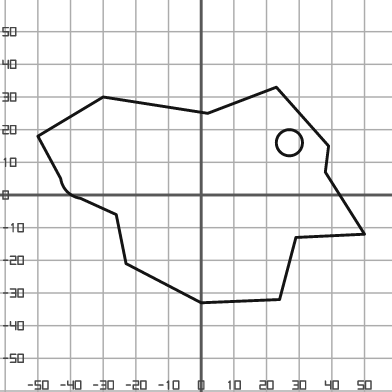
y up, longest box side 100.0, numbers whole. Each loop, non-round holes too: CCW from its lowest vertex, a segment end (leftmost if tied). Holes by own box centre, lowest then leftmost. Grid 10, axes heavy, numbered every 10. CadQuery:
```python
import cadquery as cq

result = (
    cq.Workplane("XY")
    .moveTo(0.0, -33.0)
    .lineTo(24.0, -32.0)
    .lineTo(29.0, -13.0)
    .lineTo(50.0, -12.0)
    .lineTo(38.0, 7.0)
    .lineTo(39.0, 15.0)
    .lineTo(23.0, 33.0)
    .lineTo(2.0, 25.0)
    .lineTo(-30.0, 30.0)
    .lineTo(-50.0, 18.0)
    .lineTo(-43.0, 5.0)
    .threePointArc((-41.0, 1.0), (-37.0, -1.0))
    .lineTo(-26.0, -6.0)
    .lineTo(-23.0, -21.0)
    .close()
    .moveTo(27.0, 16.0)
    .circle(4.0)
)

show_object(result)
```